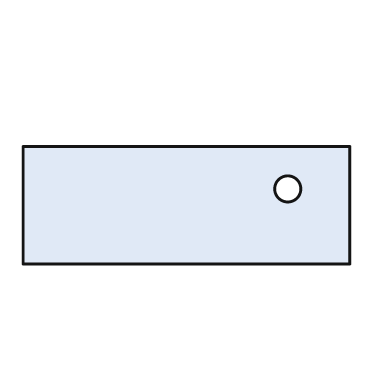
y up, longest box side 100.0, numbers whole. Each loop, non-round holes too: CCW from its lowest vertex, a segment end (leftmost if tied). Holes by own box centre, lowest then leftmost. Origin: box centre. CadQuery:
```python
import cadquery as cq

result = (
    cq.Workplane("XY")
    .moveTo(-50.0, -18.0)
    .lineTo(50.0, -18.0)
    .lineTo(50.0, 18.0)
    .lineTo(-50.0, 18.0)
    .close()
    .moveTo(31.0, 5.0)
    .circle(4.0)
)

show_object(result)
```